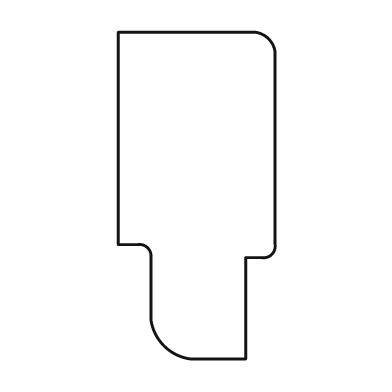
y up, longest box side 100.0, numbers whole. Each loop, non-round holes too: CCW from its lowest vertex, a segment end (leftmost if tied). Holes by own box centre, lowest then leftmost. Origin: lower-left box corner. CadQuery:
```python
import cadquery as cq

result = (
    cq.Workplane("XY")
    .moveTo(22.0, 0.0)
    .lineTo(39.0, 0.0)
    .lineTo(39.0, 31.0)
    .lineTo(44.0, 31.0)
    .threePointArc((47.0, 32.0), (48.0, 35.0))
    .lineTo(48.0, 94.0)
    .threePointArc((46.0, 98.0), (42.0, 100.0))
    .lineTo(0.0, 100.0)
    .lineTo(0.0, 35.0)
    .lineTo(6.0, 35.0)
    .threePointArc((9.0, 34.0), (10.0, 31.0))
    .lineTo(10.0, 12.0)
    .threePointArc((14.0, 4.0), (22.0, 0.0))
    .close()
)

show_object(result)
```